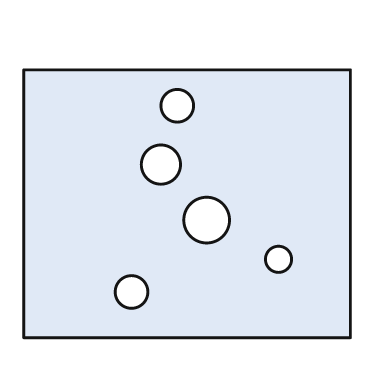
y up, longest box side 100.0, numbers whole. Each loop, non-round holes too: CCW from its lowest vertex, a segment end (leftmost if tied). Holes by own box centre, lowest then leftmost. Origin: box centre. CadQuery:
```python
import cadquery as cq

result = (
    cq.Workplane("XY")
    .moveTo(-50.0, -41.0)
    .lineTo(50.0, -41.0)
    .lineTo(50.0, 41.0)
    .lineTo(-50.0, 41.0)
    .close()
    .moveTo(-17.0, -27.0)
    .circle(5.0)
    .moveTo(28.0, -17.0)
    .circle(4.0)
    .moveTo(6.0, -5.0)
    .circle(7.0)
    .moveTo(-8.0, 12.0)
    .circle(6.0)
    .moveTo(-3.0, 30.0)
    .circle(5.0)
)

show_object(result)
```